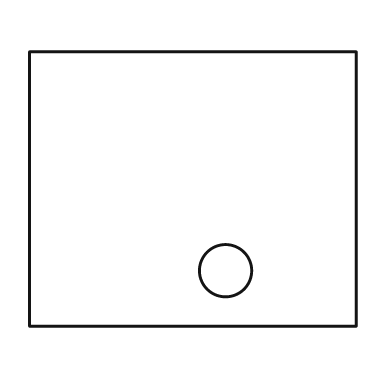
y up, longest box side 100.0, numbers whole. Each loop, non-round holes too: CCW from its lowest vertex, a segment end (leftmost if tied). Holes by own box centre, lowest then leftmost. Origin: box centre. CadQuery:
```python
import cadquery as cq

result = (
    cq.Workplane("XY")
    .moveTo(-50.0, -42.0)
    .lineTo(50.0, -42.0)
    .lineTo(50.0, 42.0)
    .lineTo(-50.0, 42.0)
    .close()
    .moveTo(10.0, -25.0)
    .circle(8.0)
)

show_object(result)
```